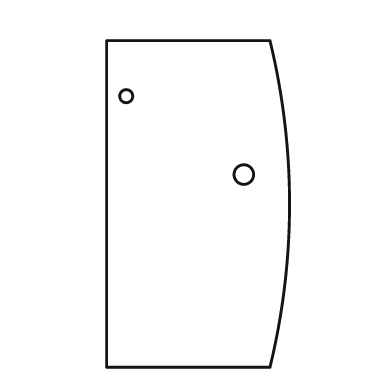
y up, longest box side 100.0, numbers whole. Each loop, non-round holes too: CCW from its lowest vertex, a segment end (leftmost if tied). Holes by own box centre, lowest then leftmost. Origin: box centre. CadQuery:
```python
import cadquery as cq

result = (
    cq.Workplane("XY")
    .moveTo(-28.0, -50.0)
    .lineTo(22.0, -50.0)
    .threePointArc((28.0, 0.0), (22.0, 50.0))
    .lineTo(-28.0, 50.0)
    .close()
    .moveTo(14.0, 9.0)
    .circle(3.0)
    .moveTo(-22.0, 33.0)
    .circle(2.0)
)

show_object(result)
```